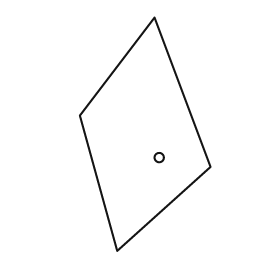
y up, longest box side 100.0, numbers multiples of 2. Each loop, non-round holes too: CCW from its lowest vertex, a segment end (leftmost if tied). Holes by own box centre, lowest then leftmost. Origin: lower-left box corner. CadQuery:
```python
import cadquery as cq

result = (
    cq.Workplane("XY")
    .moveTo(16.0, 0.0)
    .lineTo(56.0, 36.0)
    .lineTo(32.0, 100.0)
    .lineTo(0.0, 58.0)
    .close()
    .moveTo(34.0, 40.0)
    .circle(2.0)
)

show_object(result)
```